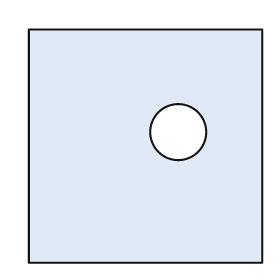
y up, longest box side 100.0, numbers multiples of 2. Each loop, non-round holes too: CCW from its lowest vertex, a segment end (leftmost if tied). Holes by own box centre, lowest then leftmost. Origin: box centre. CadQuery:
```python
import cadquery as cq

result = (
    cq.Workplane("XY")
    .moveTo(-50.0, -50.0)
    .lineTo(50.0, -50.0)
    .lineTo(50.0, 50.0)
    .lineTo(-50.0, 50.0)
    .close()
    .moveTo(14.0, 6.0)
    .circle(12.0)
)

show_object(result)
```